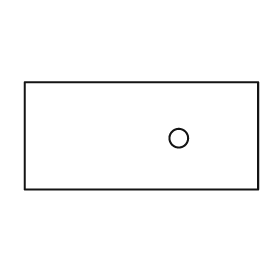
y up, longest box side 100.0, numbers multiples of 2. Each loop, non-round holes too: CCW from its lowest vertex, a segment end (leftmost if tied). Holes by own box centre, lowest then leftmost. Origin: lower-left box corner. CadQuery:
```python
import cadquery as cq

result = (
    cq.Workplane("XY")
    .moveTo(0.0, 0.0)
    .lineTo(100.0, 0.0)
    .lineTo(100.0, 46.0)
    .lineTo(0.0, 46.0)
    .close()
    .moveTo(66.0, 22.0)
    .circle(4.0)
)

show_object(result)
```